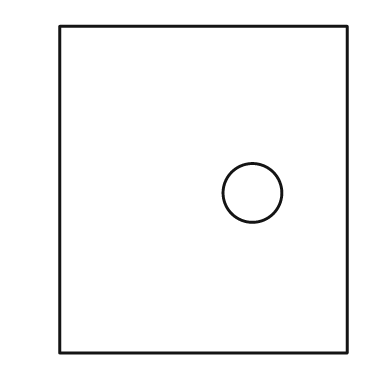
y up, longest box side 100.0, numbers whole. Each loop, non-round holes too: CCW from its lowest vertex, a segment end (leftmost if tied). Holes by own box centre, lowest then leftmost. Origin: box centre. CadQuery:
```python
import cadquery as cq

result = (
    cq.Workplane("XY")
    .moveTo(-44.0, -50.0)
    .lineTo(44.0, -50.0)
    .lineTo(44.0, 50.0)
    .lineTo(-44.0, 50.0)
    .close()
    .moveTo(15.0, -1.0)
    .circle(9.0)
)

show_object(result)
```